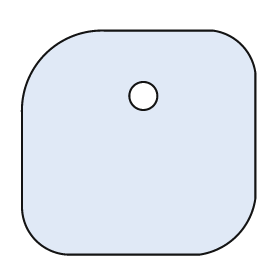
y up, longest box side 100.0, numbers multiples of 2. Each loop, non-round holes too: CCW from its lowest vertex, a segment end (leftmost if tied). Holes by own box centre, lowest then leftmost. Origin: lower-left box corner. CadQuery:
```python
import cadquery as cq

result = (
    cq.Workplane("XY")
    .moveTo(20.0, 0.0)
    .lineTo(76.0, 0.0)
    .threePointArc((92.0, 8.0), (100.0, 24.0))
    .lineTo(100.0, 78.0)
    .threePointArc((94.0, 90.0), (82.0, 96.0))
    .lineTo(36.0, 96.0)
    .threePointArc((10.0, 86.0), (0.0, 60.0))
    .lineTo(0.0, 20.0)
    .threePointArc((6.0, 6.0), (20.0, 0.0))
    .close()
    .moveTo(52.0, 68.0)
    .circle(6.0)
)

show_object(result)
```